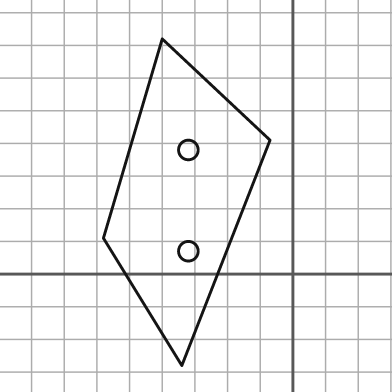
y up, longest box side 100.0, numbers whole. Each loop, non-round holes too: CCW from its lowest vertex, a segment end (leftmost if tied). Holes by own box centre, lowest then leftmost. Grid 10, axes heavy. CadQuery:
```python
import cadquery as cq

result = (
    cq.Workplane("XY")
    .moveTo(-34.0, -28.0)
    .lineTo(-7.0, 41.0)
    .lineTo(-40.0, 72.0)
    .lineTo(-58.0, 11.0)
    .close()
    .moveTo(-32.0, 7.0)
    .circle(3.0)
    .moveTo(-32.0, 38.0)
    .circle(3.0)
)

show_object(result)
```